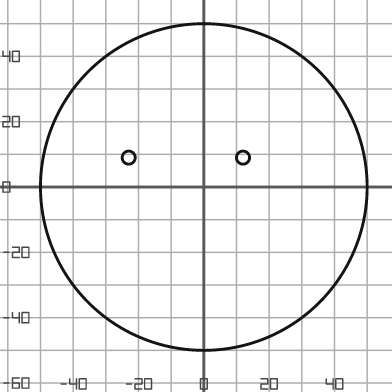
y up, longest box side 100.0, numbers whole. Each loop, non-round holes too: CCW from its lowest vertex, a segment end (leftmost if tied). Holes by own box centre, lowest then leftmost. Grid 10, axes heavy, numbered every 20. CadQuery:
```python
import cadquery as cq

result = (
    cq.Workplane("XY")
    .moveTo(0.0, 0.0)
    .circle(50.0)
    .moveTo(-23.0, 9.0)
    .circle(2.0)
    .moveTo(12.0, 9.0)
    .circle(2.0)
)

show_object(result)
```